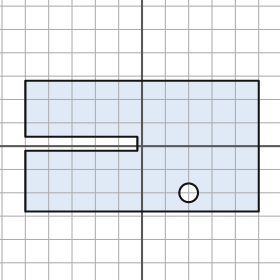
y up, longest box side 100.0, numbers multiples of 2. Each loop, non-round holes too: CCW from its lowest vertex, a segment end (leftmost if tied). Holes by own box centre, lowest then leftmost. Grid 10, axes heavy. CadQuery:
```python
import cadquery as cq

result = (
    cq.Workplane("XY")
    .moveTo(-50.0, -28.0)
    .lineTo(50.0, -28.0)
    .lineTo(50.0, 28.0)
    .lineTo(-50.0, 28.0)
    .lineTo(-50.0, 4.0)
    .lineTo(-2.0, 4.0)
    .lineTo(-2.0, -2.0)
    .lineTo(-50.0, -2.0)
    .close()
    .moveTo(20.0, -20.0)
    .circle(4.0)
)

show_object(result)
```